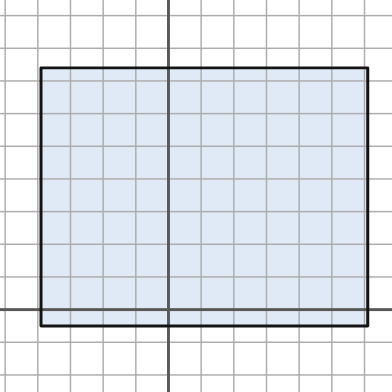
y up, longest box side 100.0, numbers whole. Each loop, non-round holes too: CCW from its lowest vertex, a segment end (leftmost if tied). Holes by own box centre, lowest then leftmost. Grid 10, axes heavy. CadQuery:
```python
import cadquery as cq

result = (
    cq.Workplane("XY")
    .moveTo(-39.0, -5.0)
    .lineTo(61.0, -5.0)
    .lineTo(61.0, 74.0)
    .lineTo(-39.0, 74.0)
    .close()
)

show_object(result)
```